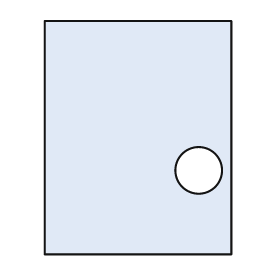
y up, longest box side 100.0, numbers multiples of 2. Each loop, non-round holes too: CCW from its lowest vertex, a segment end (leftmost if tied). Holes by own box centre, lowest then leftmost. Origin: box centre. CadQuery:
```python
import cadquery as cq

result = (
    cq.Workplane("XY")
    .moveTo(-40.0, -50.0)
    .lineTo(40.0, -50.0)
    .lineTo(40.0, 50.0)
    .lineTo(-40.0, 50.0)
    .close()
    .moveTo(26.0, -14.0)
    .circle(10.0)
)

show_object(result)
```